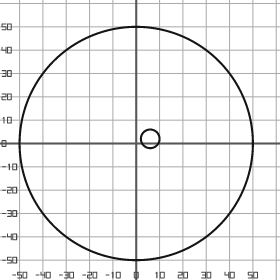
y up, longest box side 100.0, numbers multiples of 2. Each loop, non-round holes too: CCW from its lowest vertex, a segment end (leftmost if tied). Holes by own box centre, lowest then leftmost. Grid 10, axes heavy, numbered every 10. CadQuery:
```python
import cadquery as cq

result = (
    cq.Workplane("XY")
    .moveTo(0.0, 0.0)
    .circle(50.0)
    .moveTo(6.0, 2.0)
    .circle(4.0)
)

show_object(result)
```